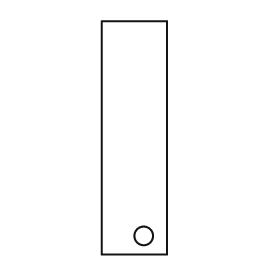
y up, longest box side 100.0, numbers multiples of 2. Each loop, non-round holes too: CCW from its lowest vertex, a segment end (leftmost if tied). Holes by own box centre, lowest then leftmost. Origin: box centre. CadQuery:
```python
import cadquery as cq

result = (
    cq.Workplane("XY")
    .moveTo(-14.0, -50.0)
    .lineTo(14.0, -50.0)
    .lineTo(14.0, 50.0)
    .lineTo(-14.0, 50.0)
    .close()
    .moveTo(4.0, -42.0)
    .circle(4.0)
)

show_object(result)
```